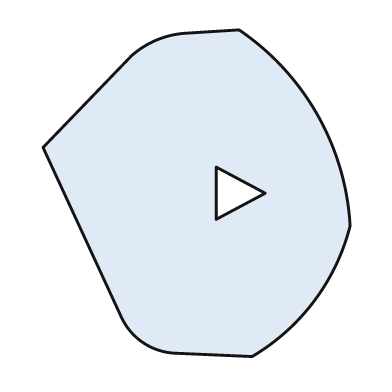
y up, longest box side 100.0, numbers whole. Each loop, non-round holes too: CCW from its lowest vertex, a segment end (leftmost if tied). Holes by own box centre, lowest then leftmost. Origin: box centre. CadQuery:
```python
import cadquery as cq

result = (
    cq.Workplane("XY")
    .moveTo(17.0, -50.0)
    .threePointArc((36.0, -33.0), (47.0, -10.0))
    .threePointArc((37.0, 24.0), (13.0, 50.0))
    .lineTo(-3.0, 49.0)
    .threePointArc((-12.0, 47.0), (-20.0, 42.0))
    .lineTo(-47.0, 14.0)
    .lineTo(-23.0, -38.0)
    .threePointArc((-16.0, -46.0), (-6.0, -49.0))
    .close()
    .moveTo(6.0, -8.0)
    .lineTo(21.0, 0.0)
    .lineTo(6.0, 8.0)
    .close()
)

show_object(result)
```